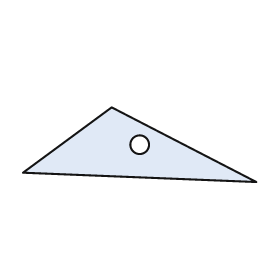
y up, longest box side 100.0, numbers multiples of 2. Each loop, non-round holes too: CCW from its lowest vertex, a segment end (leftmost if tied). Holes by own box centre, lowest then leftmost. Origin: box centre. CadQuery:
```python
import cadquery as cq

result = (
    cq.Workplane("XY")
    .moveTo(50.0, -16.0)
    .lineTo(-12.0, 16.0)
    .lineTo(-50.0, -12.0)
    .close()
    .moveTo(0.0, 0.0)
    .circle(4.0)
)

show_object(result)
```